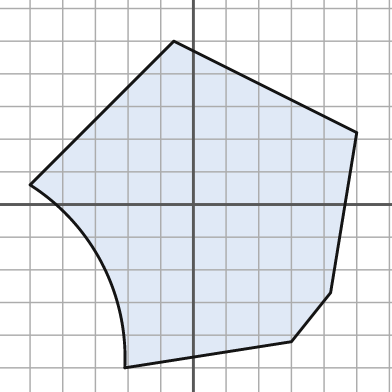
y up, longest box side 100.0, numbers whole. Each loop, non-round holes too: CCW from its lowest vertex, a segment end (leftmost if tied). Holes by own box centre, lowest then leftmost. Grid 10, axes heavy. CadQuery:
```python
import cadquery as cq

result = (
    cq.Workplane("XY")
    .moveTo(-21.0, -50.0)
    .lineTo(30.0, -42.0)
    .lineTo(42.0, -27.0)
    .lineTo(50.0, 22.0)
    .lineTo(-6.0, 50.0)
    .lineTo(-50.0, 6.0)
    .threePointArc((-28.0, -18.0), (-21.0, -50.0))
    .close()
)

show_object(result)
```